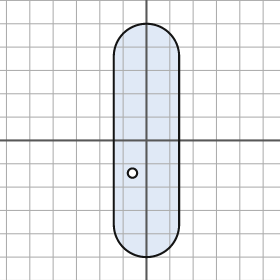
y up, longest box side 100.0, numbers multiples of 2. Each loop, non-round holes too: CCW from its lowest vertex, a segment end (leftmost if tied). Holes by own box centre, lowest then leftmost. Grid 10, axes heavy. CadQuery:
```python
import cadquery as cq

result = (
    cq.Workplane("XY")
    .moveTo(-14.0, -36.0)
    .threePointArc((0.0, -50.0), (14.0, -36.0))
    .lineTo(14.0, 36.0)
    .threePointArc((0.0, 50.0), (-14.0, 36.0))
    .close()
    .moveTo(-6.0, -14.0)
    .circle(2.0)
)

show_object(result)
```